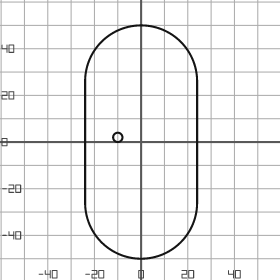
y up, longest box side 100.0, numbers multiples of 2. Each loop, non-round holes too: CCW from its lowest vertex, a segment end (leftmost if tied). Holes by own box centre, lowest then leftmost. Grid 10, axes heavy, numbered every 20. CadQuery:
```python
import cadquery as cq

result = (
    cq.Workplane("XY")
    .moveTo(-24.0, -26.0)
    .threePointArc((0.0, -50.0), (24.0, -26.0))
    .lineTo(24.0, 26.0)
    .threePointArc((0.0, 50.0), (-24.0, 26.0))
    .close()
    .moveTo(-10.0, 2.0)
    .circle(2.0)
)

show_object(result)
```